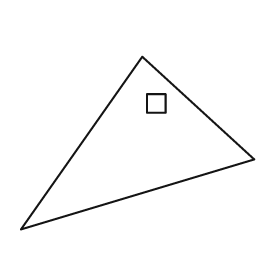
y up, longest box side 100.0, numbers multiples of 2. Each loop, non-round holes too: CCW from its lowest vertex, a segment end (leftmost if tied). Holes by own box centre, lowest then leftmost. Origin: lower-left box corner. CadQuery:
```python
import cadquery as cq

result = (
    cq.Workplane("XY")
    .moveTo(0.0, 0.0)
    .lineTo(100.0, 30.0)
    .lineTo(52.0, 74.0)
    .close()
    .moveTo(54.0, 50.0)
    .lineTo(62.0, 50.0)
    .lineTo(62.0, 58.0)
    .lineTo(54.0, 58.0)
    .close()
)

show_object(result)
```